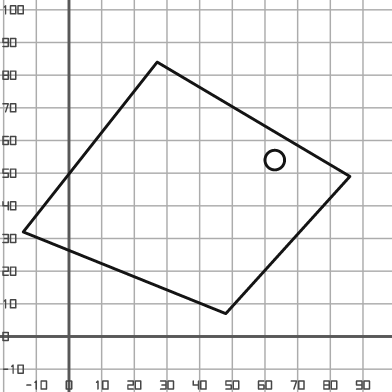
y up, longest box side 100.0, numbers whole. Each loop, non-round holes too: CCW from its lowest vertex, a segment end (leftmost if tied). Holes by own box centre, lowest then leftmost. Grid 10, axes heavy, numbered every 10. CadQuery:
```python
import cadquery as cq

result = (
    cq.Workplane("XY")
    .moveTo(48.0, 7.0)
    .lineTo(86.0, 49.0)
    .lineTo(27.0, 84.0)
    .lineTo(-14.0, 32.0)
    .close()
    .moveTo(63.0, 54.0)
    .circle(3.0)
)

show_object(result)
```